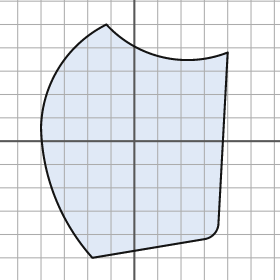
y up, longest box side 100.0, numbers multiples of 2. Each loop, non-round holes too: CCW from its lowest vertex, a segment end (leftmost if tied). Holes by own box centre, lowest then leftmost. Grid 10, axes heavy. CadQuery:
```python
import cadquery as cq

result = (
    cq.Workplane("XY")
    .moveTo(-18.0, -50.0)
    .lineTo(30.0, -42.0)
    .threePointArc((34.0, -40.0), (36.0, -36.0))
    .lineTo(40.0, 38.0)
    .threePointArc((12.0, 36.0), (-12.0, 50.0))
    .threePointArc((-32.0, 32.0), (-40.0, 6.0))
    .threePointArc((-34.0, -24.0), (-18.0, -50.0))
    .close()
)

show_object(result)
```